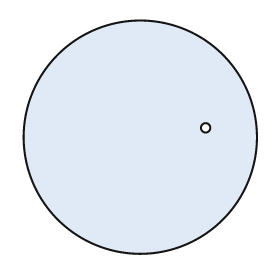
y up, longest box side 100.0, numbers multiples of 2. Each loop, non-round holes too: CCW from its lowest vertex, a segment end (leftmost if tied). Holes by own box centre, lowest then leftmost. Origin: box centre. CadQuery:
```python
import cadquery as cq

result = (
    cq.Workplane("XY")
    .moveTo(0.0, 0.0)
    .circle(50.0)
    .moveTo(28.0, 4.0)
    .circle(2.0)
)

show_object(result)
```